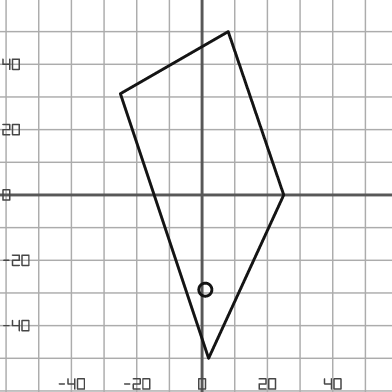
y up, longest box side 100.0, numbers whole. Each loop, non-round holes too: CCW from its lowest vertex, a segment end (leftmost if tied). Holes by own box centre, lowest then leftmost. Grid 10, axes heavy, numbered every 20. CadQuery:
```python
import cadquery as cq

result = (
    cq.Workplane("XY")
    .moveTo(2.0, -50.0)
    .lineTo(25.0, 0.0)
    .lineTo(8.0, 50.0)
    .lineTo(-25.0, 31.0)
    .close()
    .moveTo(1.0, -29.0)
    .circle(2.0)
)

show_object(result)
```